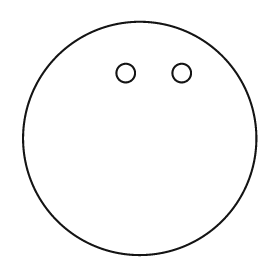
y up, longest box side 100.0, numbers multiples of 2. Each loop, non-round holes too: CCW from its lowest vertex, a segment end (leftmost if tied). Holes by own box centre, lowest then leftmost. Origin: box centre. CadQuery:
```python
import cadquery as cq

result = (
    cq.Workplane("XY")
    .moveTo(0.0, 0.0)
    .circle(50.0)
    .moveTo(-6.0, 28.0)
    .circle(4.0)
    .moveTo(18.0, 28.0)
    .circle(4.0)
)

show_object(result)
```